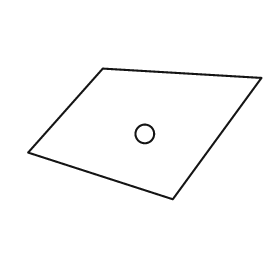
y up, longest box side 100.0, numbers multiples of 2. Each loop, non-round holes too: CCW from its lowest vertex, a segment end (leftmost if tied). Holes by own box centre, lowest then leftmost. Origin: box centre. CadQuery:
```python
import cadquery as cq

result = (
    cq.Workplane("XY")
    .moveTo(12.0, -28.0)
    .lineTo(50.0, 24.0)
    .lineTo(-18.0, 28.0)
    .lineTo(-50.0, -8.0)
    .close()
    .moveTo(0.0, 0.0)
    .circle(4.0)
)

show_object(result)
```